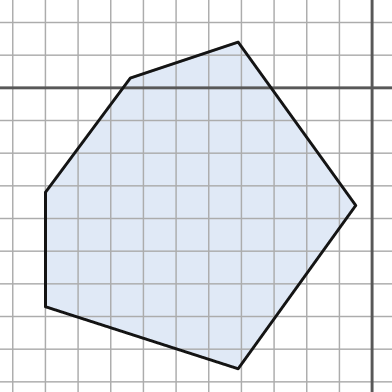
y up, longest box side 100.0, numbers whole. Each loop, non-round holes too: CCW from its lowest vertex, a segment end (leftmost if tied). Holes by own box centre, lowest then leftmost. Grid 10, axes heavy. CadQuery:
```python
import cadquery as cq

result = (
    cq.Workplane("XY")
    .moveTo(-41.0, -86.0)
    .lineTo(-5.0, -36.0)
    .lineTo(-41.0, 14.0)
    .lineTo(-74.0, 3.0)
    .lineTo(-100.0, -32.0)
    .lineTo(-100.0, -67.0)
    .close()
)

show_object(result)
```